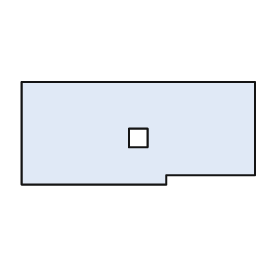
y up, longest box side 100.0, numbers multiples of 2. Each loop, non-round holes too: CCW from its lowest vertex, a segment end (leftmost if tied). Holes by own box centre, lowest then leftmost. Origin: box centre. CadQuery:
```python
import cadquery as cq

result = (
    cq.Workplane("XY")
    .moveTo(-50.0, -22.0)
    .lineTo(12.0, -22.0)
    .lineTo(12.0, -18.0)
    .lineTo(50.0, -18.0)
    .lineTo(50.0, 22.0)
    .lineTo(-50.0, 22.0)
    .close()
    .moveTo(-4.0, -6.0)
    .lineTo(4.0, -6.0)
    .lineTo(4.0, 2.0)
    .lineTo(-4.0, 2.0)
    .close()
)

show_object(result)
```